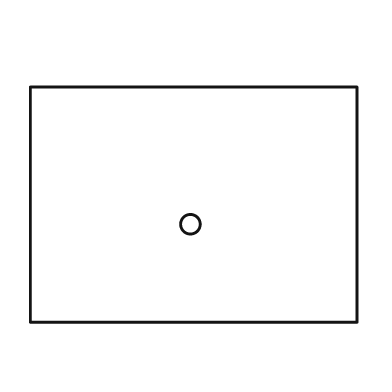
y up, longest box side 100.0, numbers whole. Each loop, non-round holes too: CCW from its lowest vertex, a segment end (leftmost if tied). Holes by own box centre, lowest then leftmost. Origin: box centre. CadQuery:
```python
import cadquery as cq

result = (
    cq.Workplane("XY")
    .moveTo(-50.0, -36.0)
    .lineTo(50.0, -36.0)
    .lineTo(50.0, 36.0)
    .lineTo(-50.0, 36.0)
    .close()
    .moveTo(-1.0, -6.0)
    .circle(3.0)
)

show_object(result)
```